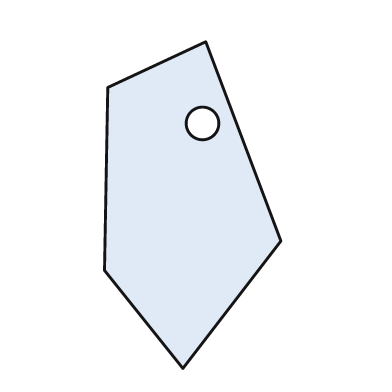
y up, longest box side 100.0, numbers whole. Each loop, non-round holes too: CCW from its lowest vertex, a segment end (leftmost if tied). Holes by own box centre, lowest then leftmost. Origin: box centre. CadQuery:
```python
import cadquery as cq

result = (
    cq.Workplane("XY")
    .moveTo(-3.0, -50.0)
    .lineTo(27.0, -11.0)
    .lineTo(4.0, 50.0)
    .lineTo(-26.0, 36.0)
    .lineTo(-27.0, -20.0)
    .close()
    .moveTo(3.0, 25.0)
    .circle(5.0)
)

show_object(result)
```